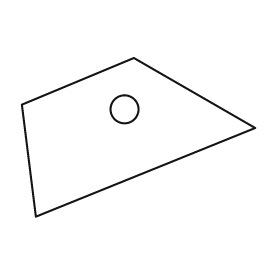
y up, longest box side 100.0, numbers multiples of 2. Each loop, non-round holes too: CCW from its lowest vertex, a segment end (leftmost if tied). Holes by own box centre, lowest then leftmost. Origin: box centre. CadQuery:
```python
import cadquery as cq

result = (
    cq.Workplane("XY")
    .moveTo(-44.0, -34.0)
    .lineTo(50.0, 4.0)
    .lineTo(-2.0, 34.0)
    .lineTo(-50.0, 14.0)
    .close()
    .moveTo(-6.0, 12.0)
    .circle(6.0)
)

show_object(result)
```